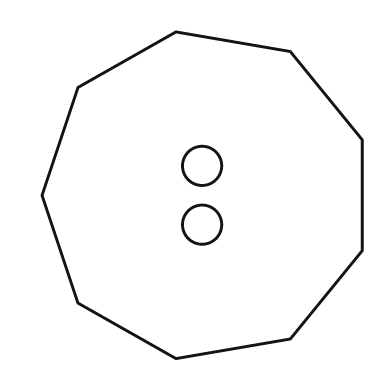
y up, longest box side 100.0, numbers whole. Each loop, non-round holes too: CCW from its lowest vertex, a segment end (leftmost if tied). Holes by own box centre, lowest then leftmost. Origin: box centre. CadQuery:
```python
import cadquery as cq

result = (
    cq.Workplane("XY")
    .moveTo(-8.0, -50.0)
    .lineTo(27.0, -44.0)
    .lineTo(49.0, -17.0)
    .lineTo(49.0, 17.0)
    .lineTo(27.0, 44.0)
    .lineTo(-8.0, 50.0)
    .lineTo(-38.0, 33.0)
    .lineTo(-49.0, 0.0)
    .lineTo(-38.0, -33.0)
    .close()
    .moveTo(0.0, -9.0)
    .circle(6.0)
    .moveTo(0.0, 9.0)
    .circle(6.0)
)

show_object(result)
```